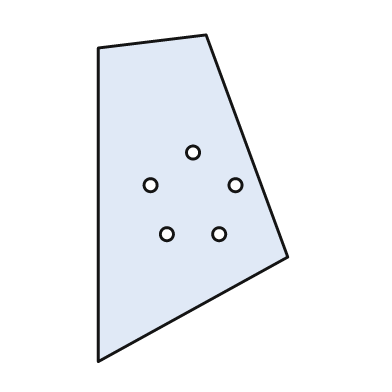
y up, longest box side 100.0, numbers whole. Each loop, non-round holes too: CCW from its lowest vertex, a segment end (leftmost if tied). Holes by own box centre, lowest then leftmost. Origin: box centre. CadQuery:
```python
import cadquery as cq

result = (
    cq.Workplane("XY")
    .moveTo(-29.0, -50.0)
    .lineTo(29.0, -18.0)
    .lineTo(4.0, 50.0)
    .lineTo(-29.0, 46.0)
    .close()
    .moveTo(-8.0, -11.0)
    .circle(2.0)
    .moveTo(8.0, -11.0)
    .circle(2.0)
    .moveTo(-13.0, 4.0)
    .circle(2.0)
    .moveTo(13.0, 4.0)
    .circle(2.0)
    .moveTo(0.0, 14.0)
    .circle(2.0)
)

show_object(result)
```